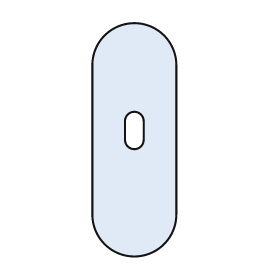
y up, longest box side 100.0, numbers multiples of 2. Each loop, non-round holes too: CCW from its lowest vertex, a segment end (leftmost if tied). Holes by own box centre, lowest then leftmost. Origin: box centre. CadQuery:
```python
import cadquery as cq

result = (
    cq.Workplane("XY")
    .moveTo(-18.0, -32.0)
    .threePointArc((0.0, -50.0), (18.0, -32.0))
    .lineTo(18.0, 32.0)
    .threePointArc((0.0, 50.0), (-18.0, 32.0))
    .close()
    .moveTo(-4.0, 0.0)
    .threePointArc((0.0, -4.0), (4.0, 0.0))
    .lineTo(4.0, 8.0)
    .threePointArc((0.0, 12.0), (-4.0, 8.0))
    .close()
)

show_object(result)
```